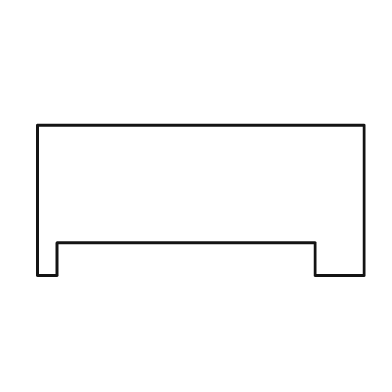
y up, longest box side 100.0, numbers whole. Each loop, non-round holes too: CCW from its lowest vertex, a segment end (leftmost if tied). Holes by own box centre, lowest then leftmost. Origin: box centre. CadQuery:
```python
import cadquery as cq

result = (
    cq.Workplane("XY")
    .moveTo(-50.0, -23.0)
    .lineTo(-44.0, -23.0)
    .lineTo(-44.0, -13.0)
    .lineTo(35.0, -13.0)
    .lineTo(35.0, -23.0)
    .lineTo(50.0, -23.0)
    .lineTo(50.0, 23.0)
    .lineTo(-50.0, 23.0)
    .close()
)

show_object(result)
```